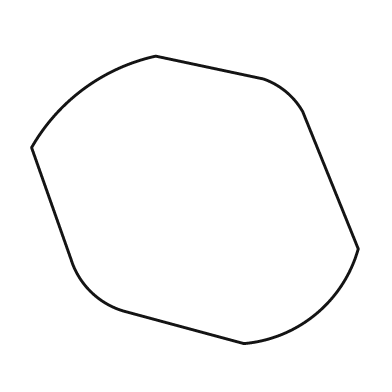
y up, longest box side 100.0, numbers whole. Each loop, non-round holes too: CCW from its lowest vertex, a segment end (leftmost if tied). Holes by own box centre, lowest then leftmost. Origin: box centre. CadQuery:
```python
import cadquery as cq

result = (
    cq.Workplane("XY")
    .moveTo(15.0, -44.0)
    .threePointArc((37.0, -35.0), (50.0, -15.0))
    .lineTo(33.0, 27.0)
    .threePointArc((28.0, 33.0), (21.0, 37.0))
    .lineTo(-12.0, 44.0)
    .threePointArc((-34.0, 34.0), (-50.0, 16.0))
    .lineTo(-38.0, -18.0)
    .threePointArc((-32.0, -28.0), (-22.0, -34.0))
    .close()
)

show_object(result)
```